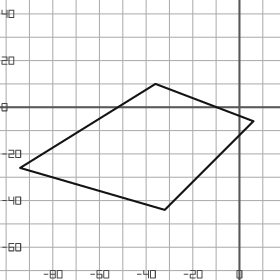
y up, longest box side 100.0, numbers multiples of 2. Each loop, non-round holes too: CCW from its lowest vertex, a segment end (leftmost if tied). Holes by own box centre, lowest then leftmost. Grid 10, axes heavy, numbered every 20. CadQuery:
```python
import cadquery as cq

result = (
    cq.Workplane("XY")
    .moveTo(-32.0, -44.0)
    .lineTo(6.0, -6.0)
    .lineTo(-36.0, 10.0)
    .lineTo(-94.0, -26.0)
    .close()
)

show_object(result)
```